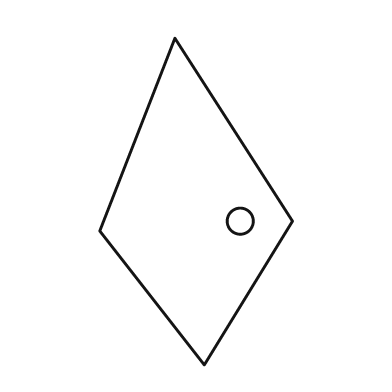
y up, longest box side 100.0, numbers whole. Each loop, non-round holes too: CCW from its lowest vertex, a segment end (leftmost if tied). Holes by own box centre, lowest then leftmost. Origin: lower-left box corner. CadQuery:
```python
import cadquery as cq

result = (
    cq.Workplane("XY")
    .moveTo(32.0, 0.0)
    .lineTo(59.0, 44.0)
    .lineTo(23.0, 100.0)
    .lineTo(0.0, 41.0)
    .close()
    .moveTo(43.0, 44.0)
    .circle(4.0)
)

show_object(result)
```